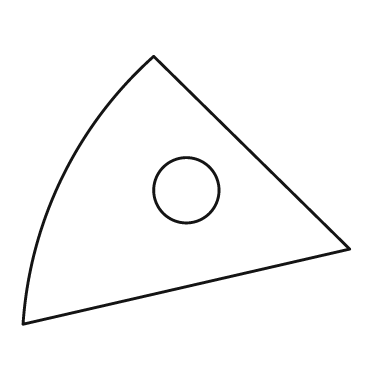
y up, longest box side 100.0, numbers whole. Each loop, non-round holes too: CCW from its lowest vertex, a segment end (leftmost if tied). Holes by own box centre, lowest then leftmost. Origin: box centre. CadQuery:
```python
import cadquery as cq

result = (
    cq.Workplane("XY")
    .moveTo(-50.0, -41.0)
    .lineTo(50.0, -18.0)
    .lineTo(-10.0, 41.0)
    .threePointArc((-38.0, 4.0), (-50.0, -41.0))
    .close()
    .moveTo(0.0, 0.0)
    .circle(10.0)
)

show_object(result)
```